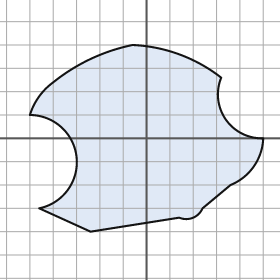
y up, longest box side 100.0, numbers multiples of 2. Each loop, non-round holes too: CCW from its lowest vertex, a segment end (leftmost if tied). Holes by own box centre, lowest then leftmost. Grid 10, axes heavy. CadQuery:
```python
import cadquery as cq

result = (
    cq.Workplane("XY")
    .moveTo(-24.0, -40.0)
    .lineTo(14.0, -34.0)
    .threePointArc((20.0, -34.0), (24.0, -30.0))
    .lineTo(36.0, -20.0)
    .threePointArc((46.0, -12.0), (50.0, 0.0))
    .threePointArc((34.0, 8.0), (32.0, 26.0))
    .threePointArc((14.0, 36.0), (-6.0, 40.0))
    .threePointArc((-24.0, 34.0), (-40.0, 24.0))
    .threePointArc((-46.0, 18.0), (-50.0, 10.0))
    .threePointArc((-30.0, -8.0), (-46.0, -30.0))
    .close()
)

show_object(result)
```